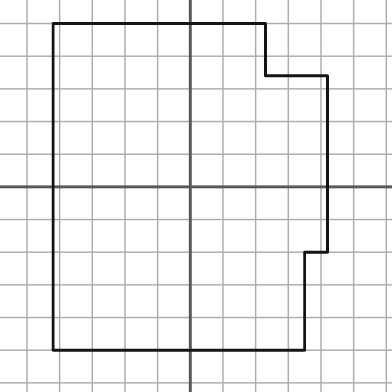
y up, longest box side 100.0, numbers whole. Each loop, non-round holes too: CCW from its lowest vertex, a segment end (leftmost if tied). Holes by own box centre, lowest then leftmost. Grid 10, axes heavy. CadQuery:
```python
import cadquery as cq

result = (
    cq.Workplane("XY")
    .moveTo(-42.0, -50.0)
    .lineTo(35.0, -50.0)
    .lineTo(35.0, -20.0)
    .lineTo(42.0, -20.0)
    .lineTo(42.0, 34.0)
    .lineTo(23.0, 34.0)
    .lineTo(23.0, 50.0)
    .lineTo(-42.0, 50.0)
    .close()
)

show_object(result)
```